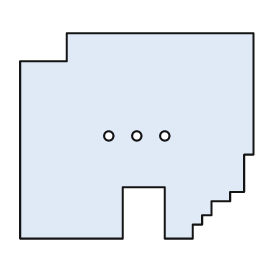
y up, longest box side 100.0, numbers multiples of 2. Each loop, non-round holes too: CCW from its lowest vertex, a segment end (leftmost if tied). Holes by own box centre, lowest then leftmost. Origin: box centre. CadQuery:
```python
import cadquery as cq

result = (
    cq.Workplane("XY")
    .moveTo(-50.0, -44.0)
    .lineTo(-6.0, -44.0)
    .lineTo(-6.0, -22.0)
    .lineTo(12.0, -22.0)
    .lineTo(12.0, -44.0)
    .lineTo(24.0, -44.0)
    .lineTo(24.0, -38.0)
    .lineTo(28.0, -38.0)
    .lineTo(28.0, -34.0)
    .lineTo(32.0, -34.0)
    .lineTo(32.0, -28.0)
    .lineTo(40.0, -28.0)
    .lineTo(40.0, -24.0)
    .lineTo(46.0, -24.0)
    .lineTo(46.0, -8.0)
    .lineTo(50.0, -8.0)
    .lineTo(50.0, 44.0)
    .lineTo(-30.0, 44.0)
    .lineTo(-30.0, 32.0)
    .lineTo(-50.0, 32.0)
    .close()
    .moveTo(-12.0, 0.0)
    .circle(2.0)
    .moveTo(0.0, 0.0)
    .circle(2.0)
    .moveTo(12.0, 0.0)
    .circle(2.0)
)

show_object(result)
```